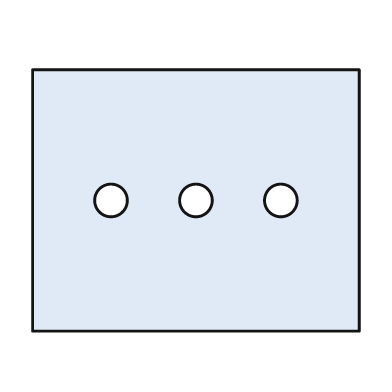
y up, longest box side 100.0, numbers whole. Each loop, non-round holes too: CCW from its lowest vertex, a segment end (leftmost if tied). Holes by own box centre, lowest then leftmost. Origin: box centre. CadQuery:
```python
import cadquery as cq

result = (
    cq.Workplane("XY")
    .moveTo(-50.0, -40.0)
    .lineTo(50.0, -40.0)
    .lineTo(50.0, 40.0)
    .lineTo(-50.0, 40.0)
    .close()
    .moveTo(-26.0, 0.0)
    .circle(5.0)
    .moveTo(0.0, 0.0)
    .circle(5.0)
    .moveTo(26.0, 0.0)
    .circle(5.0)
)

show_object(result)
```